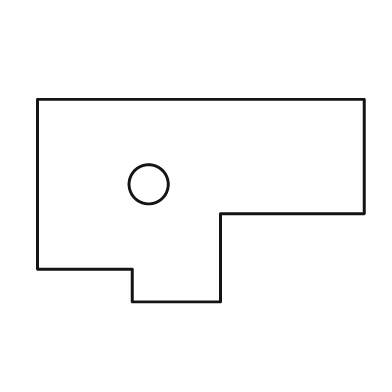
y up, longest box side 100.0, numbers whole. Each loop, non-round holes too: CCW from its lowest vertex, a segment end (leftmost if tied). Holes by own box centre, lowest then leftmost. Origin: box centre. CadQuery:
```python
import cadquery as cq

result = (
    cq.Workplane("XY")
    .moveTo(-21.0, -31.0)
    .lineTo(6.0, -31.0)
    .lineTo(6.0, -4.0)
    .lineTo(50.0, -4.0)
    .lineTo(50.0, 31.0)
    .lineTo(-50.0, 31.0)
    .lineTo(-50.0, -21.0)
    .lineTo(-21.0, -21.0)
    .close()
    .moveTo(-16.0, 5.0)
    .circle(6.0)
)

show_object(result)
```